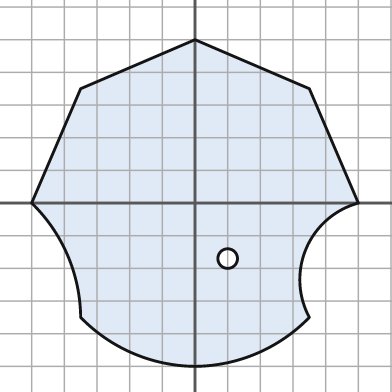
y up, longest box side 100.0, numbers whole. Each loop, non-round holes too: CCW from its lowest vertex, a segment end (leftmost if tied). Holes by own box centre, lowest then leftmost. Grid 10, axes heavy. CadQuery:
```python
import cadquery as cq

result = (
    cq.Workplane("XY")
    .moveTo(0.0, -50.0)
    .threePointArc((19.0, -46.0), (35.0, -35.0))
    .threePointArc((34.0, -14.0), (50.0, 0.0))
    .lineTo(35.0, 35.0)
    .lineTo(0.0, 50.0)
    .lineTo(-35.0, 35.0)
    .lineTo(-50.0, 0.0)
    .threePointArc((-39.0, -16.0), (-35.0, -35.0))
    .threePointArc((-19.0, -46.0), (0.0, -50.0))
    .close()
    .moveTo(10.0, -17.0)
    .circle(3.0)
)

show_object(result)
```